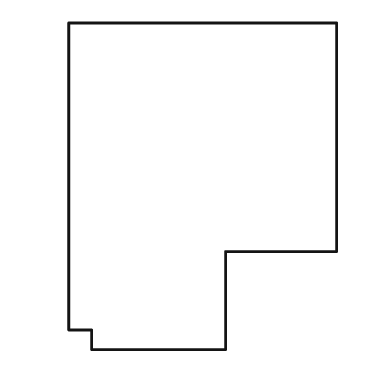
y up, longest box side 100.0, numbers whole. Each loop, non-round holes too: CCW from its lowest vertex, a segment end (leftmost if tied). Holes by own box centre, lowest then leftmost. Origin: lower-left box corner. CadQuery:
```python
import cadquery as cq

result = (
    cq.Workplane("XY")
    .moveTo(7.0, 0.0)
    .lineTo(48.0, 0.0)
    .lineTo(48.0, 30.0)
    .lineTo(82.0, 30.0)
    .lineTo(82.0, 100.0)
    .lineTo(0.0, 100.0)
    .lineTo(0.0, 6.0)
    .lineTo(7.0, 6.0)
    .close()
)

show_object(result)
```